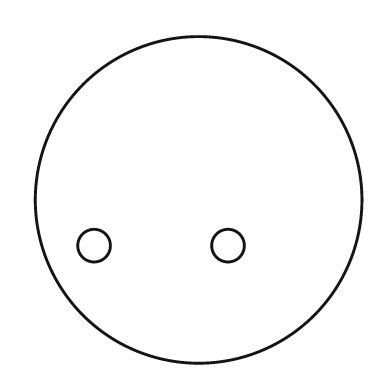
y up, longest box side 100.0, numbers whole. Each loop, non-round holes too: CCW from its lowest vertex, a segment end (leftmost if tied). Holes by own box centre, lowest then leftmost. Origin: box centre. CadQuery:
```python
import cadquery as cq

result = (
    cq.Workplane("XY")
    .moveTo(0.0, 0.0)
    .circle(50.0)
    .moveTo(-32.0, -14.0)
    .circle(5.0)
    .moveTo(9.0, -14.0)
    .circle(5.0)
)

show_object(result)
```